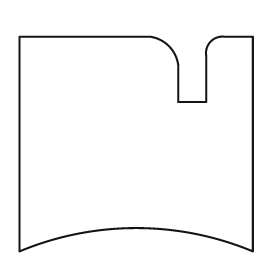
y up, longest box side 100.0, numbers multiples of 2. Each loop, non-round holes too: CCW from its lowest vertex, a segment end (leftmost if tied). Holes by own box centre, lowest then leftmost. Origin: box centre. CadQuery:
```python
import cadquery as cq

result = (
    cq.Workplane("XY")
    .moveTo(-50.0, -46.0)
    .threePointArc((0.0, -36.0), (50.0, -46.0))
    .lineTo(50.0, 46.0)
    .lineTo(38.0, 46.0)
    .threePointArc((32.0, 44.0), (30.0, 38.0))
    .lineTo(30.0, 18.0)
    .lineTo(18.0, 18.0)
    .lineTo(18.0, 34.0)
    .threePointArc((14.0, 42.0), (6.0, 46.0))
    .lineTo(-50.0, 46.0)
    .close()
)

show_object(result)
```